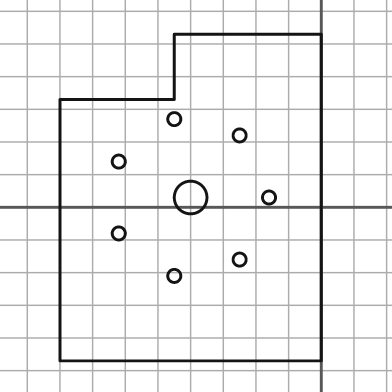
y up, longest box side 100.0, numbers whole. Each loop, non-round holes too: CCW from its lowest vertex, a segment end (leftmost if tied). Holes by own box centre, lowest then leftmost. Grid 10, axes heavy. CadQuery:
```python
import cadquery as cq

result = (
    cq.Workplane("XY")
    .moveTo(-80.0, -47.0)
    .lineTo(0.0, -47.0)
    .lineTo(0.0, 53.0)
    .lineTo(-45.0, 53.0)
    .lineTo(-45.0, 33.0)
    .lineTo(-80.0, 33.0)
    .close()
    .moveTo(-45.0, -21.0)
    .circle(2.0)
    .moveTo(-25.0, -16.0)
    .circle(2.0)
    .moveTo(-62.0, -8.0)
    .circle(2.0)
    .moveTo(-40.0, 3.0)
    .circle(5.0)
    .moveTo(-16.0, 3.0)
    .circle(2.0)
    .moveTo(-62.0, 14.0)
    .circle(2.0)
    .moveTo(-25.0, 22.0)
    .circle(2.0)
    .moveTo(-45.0, 27.0)
    .circle(2.0)
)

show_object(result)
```